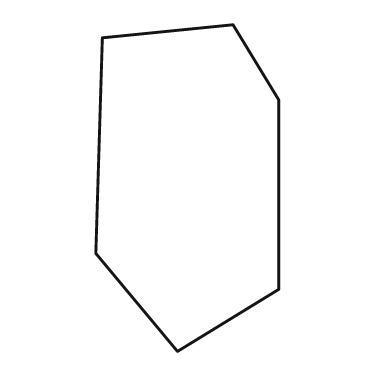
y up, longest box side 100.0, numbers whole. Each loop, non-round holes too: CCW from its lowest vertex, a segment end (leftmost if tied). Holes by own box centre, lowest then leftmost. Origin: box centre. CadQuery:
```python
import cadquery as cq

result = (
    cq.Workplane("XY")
    .moveTo(-3.0, -50.0)
    .lineTo(28.0, -31.0)
    .lineTo(28.0, 27.0)
    .lineTo(14.0, 50.0)
    .lineTo(-26.0, 46.0)
    .lineTo(-28.0, -20.0)
    .close()
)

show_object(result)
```